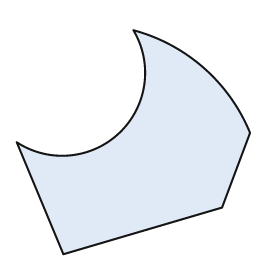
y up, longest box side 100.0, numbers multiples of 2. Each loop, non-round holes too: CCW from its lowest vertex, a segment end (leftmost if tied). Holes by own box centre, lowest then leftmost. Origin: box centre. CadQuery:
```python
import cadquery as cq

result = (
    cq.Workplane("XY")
    .moveTo(-30.0, -48.0)
    .lineTo(38.0, -28.0)
    .lineTo(50.0, 4.0)
    .threePointArc((30.0, 32.0), (0.0, 48.0))
    .threePointArc((-6.0, 4.0), (-50.0, 0.0))
    .close()
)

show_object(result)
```